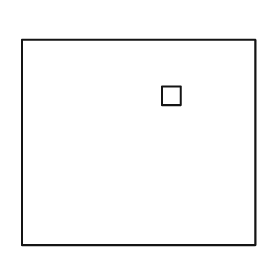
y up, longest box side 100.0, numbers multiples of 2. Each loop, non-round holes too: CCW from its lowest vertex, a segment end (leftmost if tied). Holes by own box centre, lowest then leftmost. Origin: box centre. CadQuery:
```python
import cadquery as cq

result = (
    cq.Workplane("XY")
    .moveTo(-50.0, -44.0)
    .lineTo(50.0, -44.0)
    .lineTo(50.0, 44.0)
    .lineTo(-50.0, 44.0)
    .close()
    .moveTo(10.0, 16.0)
    .lineTo(18.0, 16.0)
    .lineTo(18.0, 24.0)
    .lineTo(10.0, 24.0)
    .close()
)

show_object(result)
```